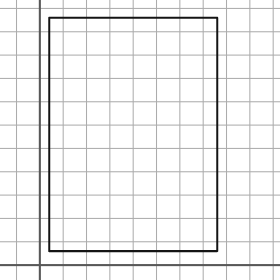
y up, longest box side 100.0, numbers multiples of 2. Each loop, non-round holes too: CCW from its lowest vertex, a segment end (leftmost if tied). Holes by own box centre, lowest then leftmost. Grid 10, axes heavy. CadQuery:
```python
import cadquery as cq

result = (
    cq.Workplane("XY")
    .moveTo(4.0, 6.0)
    .lineTo(76.0, 6.0)
    .lineTo(76.0, 106.0)
    .lineTo(4.0, 106.0)
    .close()
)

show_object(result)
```